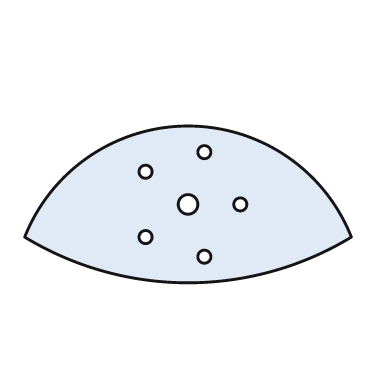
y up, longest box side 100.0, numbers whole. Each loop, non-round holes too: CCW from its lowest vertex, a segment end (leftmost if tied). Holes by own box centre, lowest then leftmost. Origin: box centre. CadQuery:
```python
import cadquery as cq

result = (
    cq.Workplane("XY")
    .moveTo(-50.0, -10.0)
    .threePointArc((0.0, -24.0), (50.0, -10.0))
    .threePointArc((0.0, 24.0), (-50.0, -10.0))
    .close()
    .moveTo(5.0, -16.0)
    .circle(2.0)
    .moveTo(-13.0, -10.0)
    .circle(2.0)
    .moveTo(0.0, 0.0)
    .circle(3.0)
    .moveTo(16.0, 0.0)
    .circle(2.0)
    .moveTo(-13.0, 10.0)
    .circle(2.0)
    .moveTo(5.0, 16.0)
    .circle(2.0)
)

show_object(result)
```